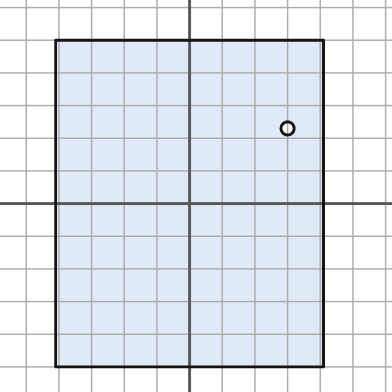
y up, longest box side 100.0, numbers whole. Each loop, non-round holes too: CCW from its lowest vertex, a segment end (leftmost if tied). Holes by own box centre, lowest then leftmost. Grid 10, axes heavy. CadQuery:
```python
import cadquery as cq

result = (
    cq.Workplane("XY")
    .moveTo(-41.0, -50.0)
    .lineTo(41.0, -50.0)
    .lineTo(41.0, 50.0)
    .lineTo(-41.0, 50.0)
    .close()
    .moveTo(30.0, 23.0)
    .circle(2.0)
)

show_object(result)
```